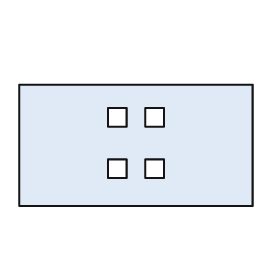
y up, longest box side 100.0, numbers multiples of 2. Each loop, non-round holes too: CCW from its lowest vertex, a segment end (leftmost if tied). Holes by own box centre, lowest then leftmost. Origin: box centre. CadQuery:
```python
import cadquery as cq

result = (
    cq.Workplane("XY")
    .moveTo(-50.0, -26.0)
    .lineTo(50.0, -26.0)
    .lineTo(50.0, 26.0)
    .lineTo(-50.0, 26.0)
    .close()
    .moveTo(-12.0, -14.0)
    .lineTo(-4.0, -14.0)
    .lineTo(-4.0, -6.0)
    .lineTo(-12.0, -6.0)
    .close()
    .moveTo(4.0, -14.0)
    .lineTo(12.0, -14.0)
    .lineTo(12.0, -6.0)
    .lineTo(4.0, -6.0)
    .close()
    .moveTo(-12.0, 8.0)
    .lineTo(-4.0, 8.0)
    .lineTo(-4.0, 16.0)
    .lineTo(-12.0, 16.0)
    .close()
    .moveTo(4.0, 8.0)
    .lineTo(12.0, 8.0)
    .lineTo(12.0, 16.0)
    .lineTo(4.0, 16.0)
    .close()
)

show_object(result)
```